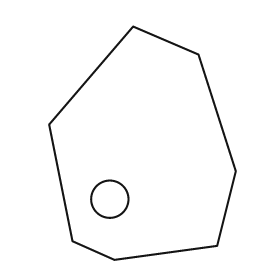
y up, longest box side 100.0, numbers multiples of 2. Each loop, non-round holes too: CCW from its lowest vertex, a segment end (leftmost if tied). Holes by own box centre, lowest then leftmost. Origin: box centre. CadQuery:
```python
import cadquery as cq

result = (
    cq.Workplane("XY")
    .moveTo(-12.0, -50.0)
    .lineTo(32.0, -44.0)
    .lineTo(40.0, -12.0)
    .lineTo(24.0, 38.0)
    .lineTo(-4.0, 50.0)
    .lineTo(-40.0, 8.0)
    .lineTo(-30.0, -42.0)
    .close()
    .moveTo(-14.0, -24.0)
    .circle(8.0)
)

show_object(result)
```